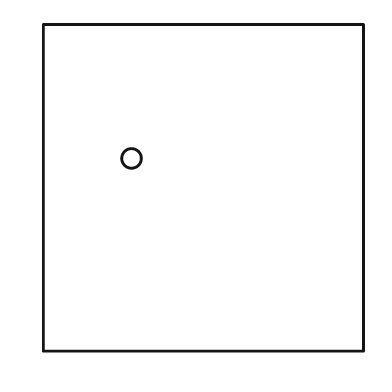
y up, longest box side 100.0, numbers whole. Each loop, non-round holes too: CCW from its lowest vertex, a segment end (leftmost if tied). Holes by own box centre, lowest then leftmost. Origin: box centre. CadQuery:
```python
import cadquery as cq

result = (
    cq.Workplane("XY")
    .moveTo(-49.0, -50.0)
    .lineTo(49.0, -50.0)
    .lineTo(49.0, 50.0)
    .lineTo(-49.0, 50.0)
    .close()
    .moveTo(-22.0, 9.0)
    .circle(3.0)
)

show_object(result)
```